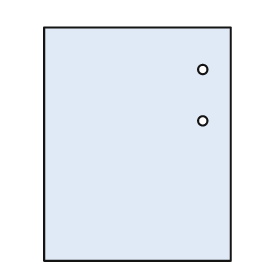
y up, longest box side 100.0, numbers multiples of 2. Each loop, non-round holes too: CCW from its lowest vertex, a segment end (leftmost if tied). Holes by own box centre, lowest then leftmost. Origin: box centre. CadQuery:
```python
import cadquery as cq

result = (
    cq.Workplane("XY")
    .moveTo(-40.0, -50.0)
    .lineTo(40.0, -50.0)
    .lineTo(40.0, 50.0)
    .lineTo(-40.0, 50.0)
    .close()
    .moveTo(28.0, 10.0)
    .circle(2.0)
    .moveTo(28.0, 32.0)
    .circle(2.0)
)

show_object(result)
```